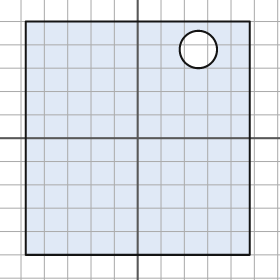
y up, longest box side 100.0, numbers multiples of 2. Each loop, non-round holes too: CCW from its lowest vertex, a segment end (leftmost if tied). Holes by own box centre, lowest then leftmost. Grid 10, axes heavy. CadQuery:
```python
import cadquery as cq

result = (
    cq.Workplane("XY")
    .moveTo(-48.0, -50.0)
    .lineTo(48.0, -50.0)
    .lineTo(48.0, 50.0)
    .lineTo(-48.0, 50.0)
    .close()
    .moveTo(26.0, 38.0)
    .circle(8.0)
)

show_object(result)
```